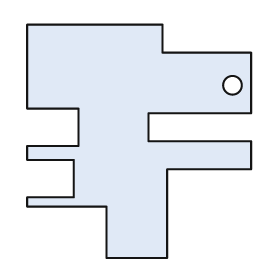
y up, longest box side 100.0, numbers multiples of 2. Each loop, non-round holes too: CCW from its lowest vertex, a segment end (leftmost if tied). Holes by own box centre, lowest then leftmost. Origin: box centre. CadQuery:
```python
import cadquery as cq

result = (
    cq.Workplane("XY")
    .moveTo(-14.0, -50.0)
    .lineTo(12.0, -50.0)
    .lineTo(12.0, -12.0)
    .lineTo(48.0, -12.0)
    .lineTo(48.0, 0.0)
    .lineTo(4.0, 0.0)
    .lineTo(4.0, 12.0)
    .lineTo(48.0, 12.0)
    .lineTo(48.0, 38.0)
    .lineTo(10.0, 38.0)
    .lineTo(10.0, 50.0)
    .lineTo(-48.0, 50.0)
    .lineTo(-48.0, 14.0)
    .lineTo(-26.0, 14.0)
    .lineTo(-26.0, -2.0)
    .lineTo(-48.0, -2.0)
    .lineTo(-48.0, -8.0)
    .lineTo(-28.0, -8.0)
    .lineTo(-28.0, -24.0)
    .lineTo(-48.0, -24.0)
    .lineTo(-48.0, -28.0)
    .lineTo(-14.0, -28.0)
    .close()
    .moveTo(40.0, 24.0)
    .circle(4.0)
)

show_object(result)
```